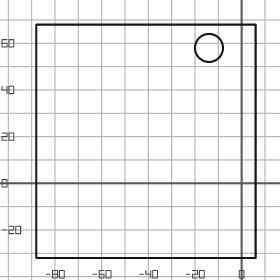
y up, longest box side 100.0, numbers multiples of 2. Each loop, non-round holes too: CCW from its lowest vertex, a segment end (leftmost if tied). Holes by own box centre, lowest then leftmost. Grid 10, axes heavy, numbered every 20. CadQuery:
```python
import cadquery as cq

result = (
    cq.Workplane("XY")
    .moveTo(-88.0, -32.0)
    .lineTo(6.0, -32.0)
    .lineTo(6.0, 68.0)
    .lineTo(-88.0, 68.0)
    .close()
    .moveTo(-14.0, 58.0)
    .circle(6.0)
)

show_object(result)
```